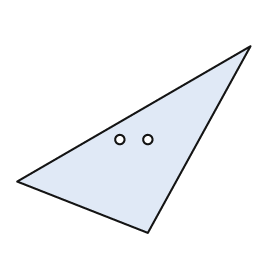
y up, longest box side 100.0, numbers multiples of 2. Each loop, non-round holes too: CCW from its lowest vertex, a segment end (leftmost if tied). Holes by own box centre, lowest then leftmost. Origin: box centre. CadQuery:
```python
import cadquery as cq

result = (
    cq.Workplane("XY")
    .moveTo(6.0, -40.0)
    .lineTo(50.0, 40.0)
    .lineTo(-50.0, -18.0)
    .close()
    .moveTo(-6.0, 0.0)
    .circle(2.0)
    .moveTo(6.0, 0.0)
    .circle(2.0)
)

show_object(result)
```